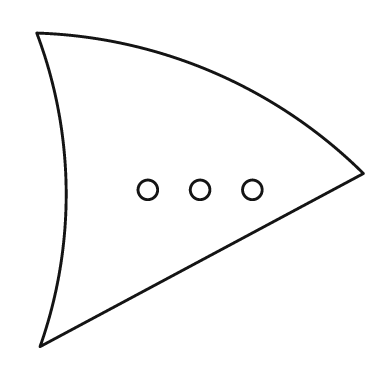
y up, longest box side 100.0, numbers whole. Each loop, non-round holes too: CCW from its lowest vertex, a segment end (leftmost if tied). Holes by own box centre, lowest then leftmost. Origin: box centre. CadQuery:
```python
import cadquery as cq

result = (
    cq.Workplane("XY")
    .moveTo(-49.0, -48.0)
    .lineTo(50.0, 5.0)
    .threePointArc((4.0, 36.0), (-50.0, 48.0))
    .threePointArc((-41.0, 0.0), (-49.0, -48.0))
    .close()
    .moveTo(-16.0, 0.0)
    .circle(3.0)
    .moveTo(0.0, 0.0)
    .circle(3.0)
    .moveTo(16.0, 0.0)
    .circle(3.0)
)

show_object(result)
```